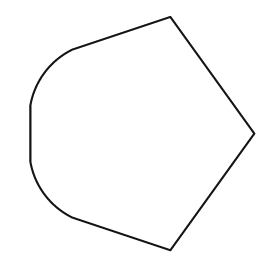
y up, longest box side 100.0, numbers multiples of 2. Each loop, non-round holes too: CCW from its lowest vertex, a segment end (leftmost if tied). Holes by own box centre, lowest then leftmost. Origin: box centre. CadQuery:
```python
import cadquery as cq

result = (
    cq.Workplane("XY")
    .moveTo(12.0, -50.0)
    .lineTo(48.0, 0.0)
    .lineTo(12.0, 50.0)
    .lineTo(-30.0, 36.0)
    .threePointArc((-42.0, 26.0), (-48.0, 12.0))
    .lineTo(-48.0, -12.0)
    .threePointArc((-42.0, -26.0), (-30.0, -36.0))
    .close()
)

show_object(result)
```